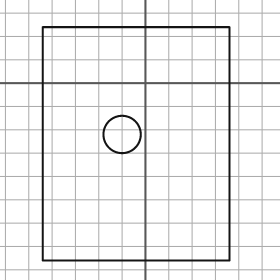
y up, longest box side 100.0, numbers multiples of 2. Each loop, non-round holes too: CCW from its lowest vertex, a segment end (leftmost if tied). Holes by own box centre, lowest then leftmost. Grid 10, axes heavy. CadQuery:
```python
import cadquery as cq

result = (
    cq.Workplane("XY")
    .moveTo(-44.0, -76.0)
    .lineTo(36.0, -76.0)
    .lineTo(36.0, 24.0)
    .lineTo(-44.0, 24.0)
    .close()
    .moveTo(-10.0, -22.0)
    .circle(8.0)
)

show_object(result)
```